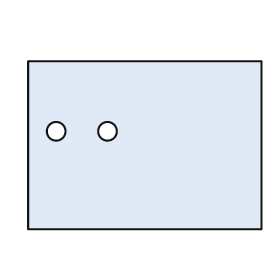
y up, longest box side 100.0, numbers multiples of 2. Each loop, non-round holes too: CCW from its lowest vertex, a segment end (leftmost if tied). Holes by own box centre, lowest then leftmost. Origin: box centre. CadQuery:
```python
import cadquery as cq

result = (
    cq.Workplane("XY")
    .moveTo(-50.0, -36.0)
    .lineTo(50.0, -36.0)
    .lineTo(50.0, 36.0)
    .lineTo(-50.0, 36.0)
    .close()
    .moveTo(-38.0, 6.0)
    .circle(4.0)
    .moveTo(-16.0, 6.0)
    .circle(4.0)
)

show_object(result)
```